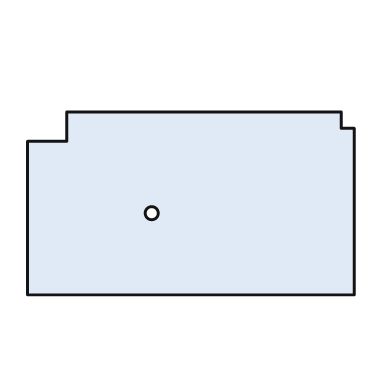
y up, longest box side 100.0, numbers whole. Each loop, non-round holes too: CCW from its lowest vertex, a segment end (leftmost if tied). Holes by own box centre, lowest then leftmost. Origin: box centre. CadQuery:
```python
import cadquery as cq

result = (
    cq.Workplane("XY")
    .moveTo(-50.0, -28.0)
    .lineTo(50.0, -28.0)
    .lineTo(50.0, 23.0)
    .lineTo(46.0, 23.0)
    .lineTo(46.0, 28.0)
    .lineTo(-38.0, 28.0)
    .lineTo(-38.0, 19.0)
    .lineTo(-50.0, 19.0)
    .close()
    .moveTo(-12.0, -3.0)
    .circle(2.0)
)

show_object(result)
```